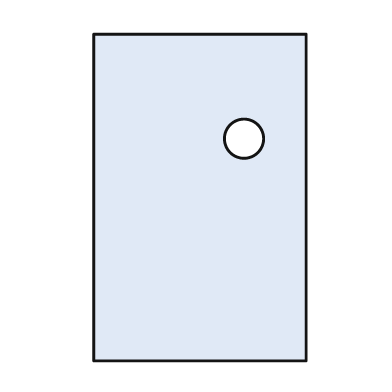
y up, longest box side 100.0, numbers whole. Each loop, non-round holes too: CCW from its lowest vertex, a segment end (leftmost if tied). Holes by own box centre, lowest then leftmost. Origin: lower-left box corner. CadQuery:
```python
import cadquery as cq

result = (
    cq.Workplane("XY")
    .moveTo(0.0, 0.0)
    .lineTo(65.0, 0.0)
    .lineTo(65.0, 100.0)
    .lineTo(0.0, 100.0)
    .close()
    .moveTo(46.0, 68.0)
    .circle(6.0)
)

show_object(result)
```